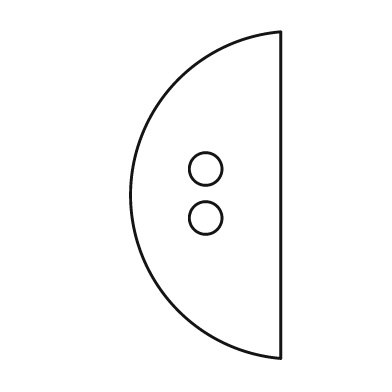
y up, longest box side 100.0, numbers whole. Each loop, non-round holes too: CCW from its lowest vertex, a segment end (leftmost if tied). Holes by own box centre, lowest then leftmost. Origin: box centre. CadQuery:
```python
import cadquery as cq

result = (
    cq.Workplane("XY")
    .moveTo(23.0, -50.0)
    .lineTo(23.0, 50.0)
    .threePointArc((-23.0, 0.0), (23.0, -50.0))
    .close()
    .moveTo(0.0, -7.0)
    .circle(5.0)
    .moveTo(0.0, 8.0)
    .circle(5.0)
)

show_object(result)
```